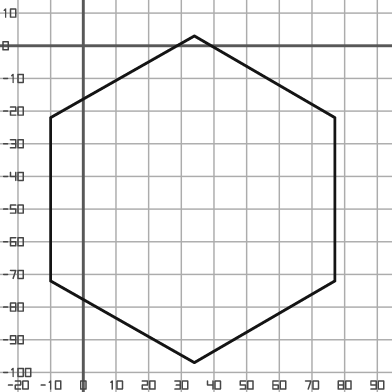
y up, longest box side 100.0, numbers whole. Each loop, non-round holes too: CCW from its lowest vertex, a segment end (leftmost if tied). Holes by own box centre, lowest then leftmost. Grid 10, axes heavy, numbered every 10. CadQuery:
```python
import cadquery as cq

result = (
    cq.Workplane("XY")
    .moveTo(34.0, -97.0)
    .lineTo(77.0, -72.0)
    .lineTo(77.0, -22.0)
    .lineTo(34.0, 3.0)
    .lineTo(-10.0, -22.0)
    .lineTo(-10.0, -72.0)
    .close()
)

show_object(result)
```